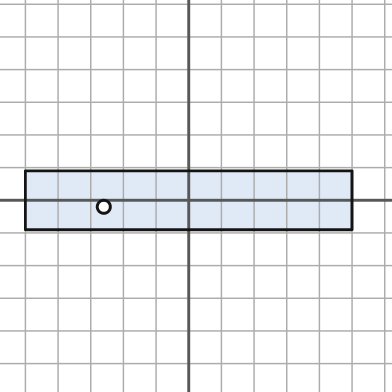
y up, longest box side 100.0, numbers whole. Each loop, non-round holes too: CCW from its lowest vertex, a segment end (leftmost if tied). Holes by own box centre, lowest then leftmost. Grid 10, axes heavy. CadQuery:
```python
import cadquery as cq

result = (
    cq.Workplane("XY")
    .moveTo(-50.0, -9.0)
    .lineTo(50.0, -9.0)
    .lineTo(50.0, 9.0)
    .lineTo(-50.0, 9.0)
    .close()
    .moveTo(-26.0, -2.0)
    .circle(2.0)
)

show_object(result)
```